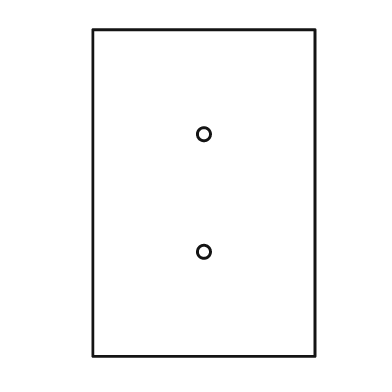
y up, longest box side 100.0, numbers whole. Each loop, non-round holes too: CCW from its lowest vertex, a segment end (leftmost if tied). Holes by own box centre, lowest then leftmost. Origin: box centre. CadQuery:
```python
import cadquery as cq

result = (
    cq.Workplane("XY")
    .moveTo(-34.0, -50.0)
    .lineTo(34.0, -50.0)
    .lineTo(34.0, 50.0)
    .lineTo(-34.0, 50.0)
    .close()
    .moveTo(0.0, -18.0)
    .circle(2.0)
    .moveTo(0.0, 18.0)
    .circle(2.0)
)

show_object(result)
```